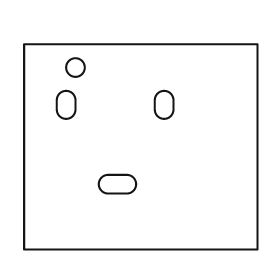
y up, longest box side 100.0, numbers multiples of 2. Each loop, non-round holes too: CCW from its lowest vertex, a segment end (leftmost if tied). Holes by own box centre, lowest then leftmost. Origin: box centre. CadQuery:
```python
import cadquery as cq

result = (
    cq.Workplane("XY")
    .moveTo(-50.0, -44.0)
    .lineTo(50.0, -44.0)
    .lineTo(50.0, 44.0)
    .lineTo(-50.0, 44.0)
    .close()
    .moveTo(-14.0, -20.0)
    .lineTo(-6.0, -20.0)
    .threePointArc((-2.0, -16.0), (-6.0, -12.0))
    .lineTo(-14.0, -12.0)
    .threePointArc((-18.0, -16.0), (-14.0, -20.0))
    .close()
    .moveTo(-36.0, 16.0)
    .threePointArc((-32.0, 12.0), (-28.0, 16.0))
    .lineTo(-28.0, 20.0)
    .threePointArc((-32.0, 24.0), (-36.0, 20.0))
    .close()
    .moveTo(6.0, 16.0)
    .threePointArc((10.0, 12.0), (14.0, 16.0))
    .lineTo(14.0, 20.0)
    .threePointArc((10.0, 24.0), (6.0, 20.0))
    .close()
    .moveTo(-28.0, 34.0)
    .circle(4.0)
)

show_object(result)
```